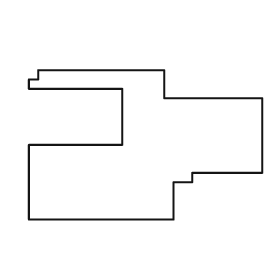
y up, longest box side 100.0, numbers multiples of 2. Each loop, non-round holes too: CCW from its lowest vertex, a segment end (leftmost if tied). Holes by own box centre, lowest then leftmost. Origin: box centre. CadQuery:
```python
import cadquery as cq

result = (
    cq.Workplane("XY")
    .moveTo(-50.0, -32.0)
    .lineTo(12.0, -32.0)
    .lineTo(12.0, -16.0)
    .lineTo(20.0, -16.0)
    .lineTo(20.0, -12.0)
    .lineTo(50.0, -12.0)
    .lineTo(50.0, 20.0)
    .lineTo(8.0, 20.0)
    .lineTo(8.0, 32.0)
    .lineTo(-46.0, 32.0)
    .lineTo(-46.0, 28.0)
    .lineTo(-50.0, 28.0)
    .lineTo(-50.0, 24.0)
    .lineTo(-10.0, 24.0)
    .lineTo(-10.0, 0.0)
    .lineTo(-50.0, 0.0)
    .close()
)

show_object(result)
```